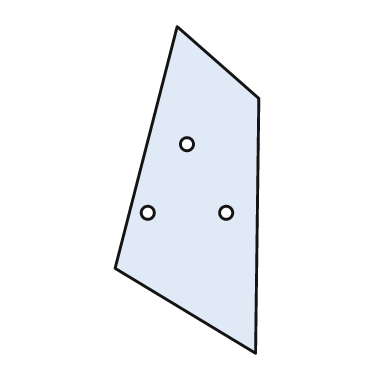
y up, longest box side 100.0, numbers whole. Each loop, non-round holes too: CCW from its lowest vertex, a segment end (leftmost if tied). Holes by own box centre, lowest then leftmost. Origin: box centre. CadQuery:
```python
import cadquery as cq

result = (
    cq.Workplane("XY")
    .moveTo(21.0, -50.0)
    .lineTo(22.0, 28.0)
    .lineTo(-3.0, 50.0)
    .lineTo(-22.0, -24.0)
    .close()
    .moveTo(-12.0, -7.0)
    .circle(2.0)
    .moveTo(12.0, -7.0)
    .circle(2.0)
    .moveTo(0.0, 14.0)
    .circle(2.0)
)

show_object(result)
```